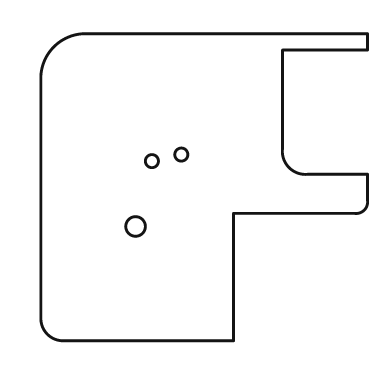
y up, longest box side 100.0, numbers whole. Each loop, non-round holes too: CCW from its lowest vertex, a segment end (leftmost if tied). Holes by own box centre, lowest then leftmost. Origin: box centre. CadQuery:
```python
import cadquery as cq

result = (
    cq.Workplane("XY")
    .moveTo(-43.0, -47.0)
    .lineTo(9.0, -47.0)
    .lineTo(9.0, -8.0)
    .lineTo(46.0, -8.0)
    .threePointArc((49.0, -7.0), (50.0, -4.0))
    .lineTo(50.0, 4.0)
    .lineTo(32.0, 4.0)
    .threePointArc((26.0, 6.0), (24.0, 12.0))
    .lineTo(24.0, 42.0)
    .lineTo(50.0, 42.0)
    .lineTo(50.0, 47.0)
    .lineTo(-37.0, 47.0)
    .threePointArc((-46.0, 43.0), (-50.0, 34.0))
    .lineTo(-50.0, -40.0)
    .threePointArc((-48.0, -45.0), (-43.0, -47.0))
    .close()
    .moveTo(-21.0, -12.0)
    .circle(3.0)
    .moveTo(-16.0, 8.0)
    .circle(2.0)
    .moveTo(-7.0, 10.0)
    .circle(2.0)
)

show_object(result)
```